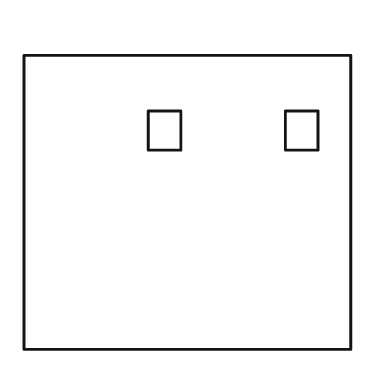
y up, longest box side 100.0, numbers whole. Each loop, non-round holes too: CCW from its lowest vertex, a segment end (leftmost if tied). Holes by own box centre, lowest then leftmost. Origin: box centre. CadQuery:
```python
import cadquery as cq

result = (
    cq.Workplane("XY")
    .moveTo(-50.0, -45.0)
    .lineTo(50.0, -45.0)
    .lineTo(50.0, 45.0)
    .lineTo(-50.0, 45.0)
    .close()
    .moveTo(-12.0, 16.0)
    .lineTo(-2.0, 16.0)
    .lineTo(-2.0, 28.0)
    .lineTo(-12.0, 28.0)
    .close()
    .moveTo(30.0, 16.0)
    .lineTo(40.0, 16.0)
    .lineTo(40.0, 28.0)
    .lineTo(30.0, 28.0)
    .close()
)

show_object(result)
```